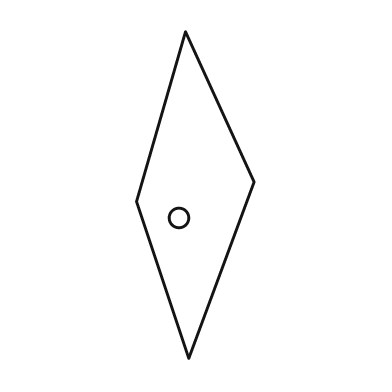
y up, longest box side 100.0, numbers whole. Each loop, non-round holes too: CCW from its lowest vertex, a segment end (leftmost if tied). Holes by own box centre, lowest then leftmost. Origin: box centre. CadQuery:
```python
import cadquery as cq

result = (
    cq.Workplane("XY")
    .moveTo(-2.0, -50.0)
    .lineTo(18.0, 4.0)
    .lineTo(-3.0, 50.0)
    .lineTo(-18.0, -2.0)
    .close()
    .moveTo(-5.0, -7.0)
    .circle(3.0)
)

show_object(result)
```